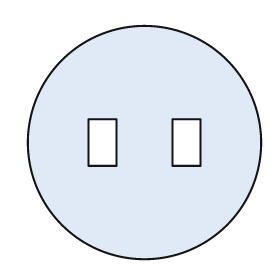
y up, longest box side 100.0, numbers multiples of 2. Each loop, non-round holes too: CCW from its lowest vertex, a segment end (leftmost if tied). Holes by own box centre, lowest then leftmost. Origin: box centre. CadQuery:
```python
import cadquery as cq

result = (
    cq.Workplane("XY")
    .moveTo(0.0, 0.0)
    .circle(50.0)
    .moveTo(-24.0, -10.0)
    .lineTo(-12.0, -10.0)
    .lineTo(-12.0, 10.0)
    .lineTo(-24.0, 10.0)
    .close()
    .moveTo(12.0, -10.0)
    .lineTo(24.0, -10.0)
    .lineTo(24.0, 10.0)
    .lineTo(12.0, 10.0)
    .close()
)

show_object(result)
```